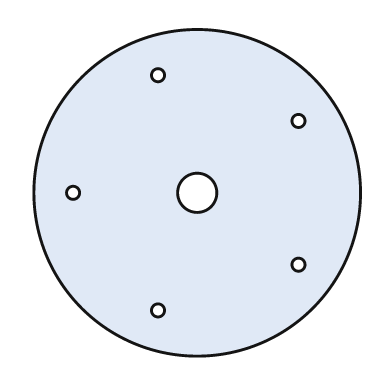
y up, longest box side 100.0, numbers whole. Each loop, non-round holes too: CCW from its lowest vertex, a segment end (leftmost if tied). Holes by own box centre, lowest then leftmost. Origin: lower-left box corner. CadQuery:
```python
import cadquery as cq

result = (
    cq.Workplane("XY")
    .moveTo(50.0, 50.0)
    .circle(50.0)
    .moveTo(38.0, 14.0)
    .circle(2.0)
    .moveTo(81.0, 28.0)
    .circle(2.0)
    .moveTo(12.0, 50.0)
    .circle(2.0)
    .moveTo(50.0, 50.0)
    .circle(6.0)
    .moveTo(81.0, 72.0)
    .circle(2.0)
    .moveTo(38.0, 86.0)
    .circle(2.0)
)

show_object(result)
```